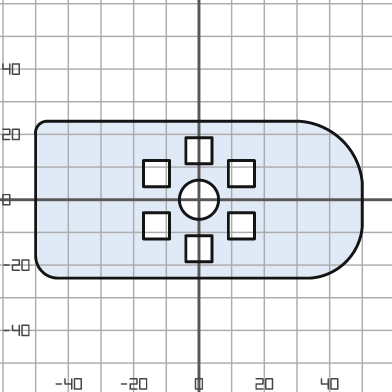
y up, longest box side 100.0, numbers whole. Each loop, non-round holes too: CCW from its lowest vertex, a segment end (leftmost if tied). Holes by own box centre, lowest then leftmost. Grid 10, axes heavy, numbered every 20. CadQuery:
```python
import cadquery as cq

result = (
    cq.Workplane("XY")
    .moveTo(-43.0, -24.0)
    .lineTo(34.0, -24.0)
    .threePointArc((45.0, -19.0), (50.0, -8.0))
    .lineTo(50.0, 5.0)
    .threePointArc((44.0, 18.0), (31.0, 24.0))
    .lineTo(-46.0, 24.0)
    .threePointArc((-49.0, 23.0), (-50.0, 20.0))
    .lineTo(-50.0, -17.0)
    .threePointArc((-48.0, -22.0), (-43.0, -24.0))
    .close()
    .moveTo(-4.0, -19.0)
    .lineTo(4.0, -19.0)
    .lineTo(4.0, -11.0)
    .lineTo(-4.0, -11.0)
    .close()
    .moveTo(-17.0, -12.0)
    .lineTo(-9.0, -12.0)
    .lineTo(-9.0, -4.0)
    .lineTo(-17.0, -4.0)
    .close()
    .moveTo(9.0, -12.0)
    .lineTo(17.0, -12.0)
    .lineTo(17.0, -4.0)
    .lineTo(9.0, -4.0)
    .close()
    .moveTo(0.0, 0.0)
    .circle(6.0)
    .moveTo(-17.0, 4.0)
    .lineTo(-9.0, 4.0)
    .lineTo(-9.0, 12.0)
    .lineTo(-17.0, 12.0)
    .close()
    .moveTo(9.0, 4.0)
    .lineTo(17.0, 4.0)
    .lineTo(17.0, 12.0)
    .lineTo(9.0, 12.0)
    .close()
    .moveTo(-4.0, 11.0)
    .lineTo(4.0, 11.0)
    .lineTo(4.0, 19.0)
    .lineTo(-4.0, 19.0)
    .close()
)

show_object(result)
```